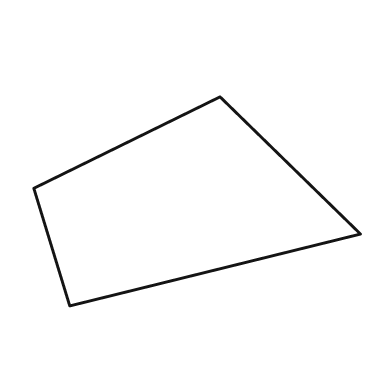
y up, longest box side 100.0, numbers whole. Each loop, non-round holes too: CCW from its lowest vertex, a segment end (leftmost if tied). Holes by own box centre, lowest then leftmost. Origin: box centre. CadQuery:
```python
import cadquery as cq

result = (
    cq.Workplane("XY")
    .moveTo(-39.0, -32.0)
    .lineTo(50.0, -10.0)
    .lineTo(7.0, 32.0)
    .lineTo(-50.0, 4.0)
    .close()
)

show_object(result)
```